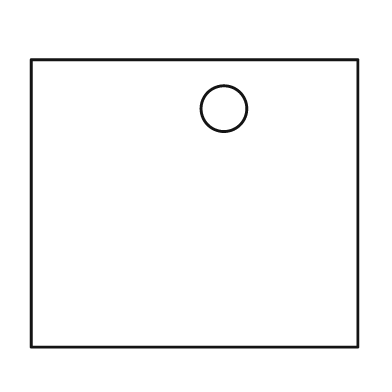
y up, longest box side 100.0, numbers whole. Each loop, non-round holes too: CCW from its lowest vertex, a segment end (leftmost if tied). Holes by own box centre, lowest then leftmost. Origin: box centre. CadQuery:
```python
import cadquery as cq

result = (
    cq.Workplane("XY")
    .moveTo(-50.0, -44.0)
    .lineTo(50.0, -44.0)
    .lineTo(50.0, 44.0)
    .lineTo(-50.0, 44.0)
    .close()
    .moveTo(9.0, 29.0)
    .circle(7.0)
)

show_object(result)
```